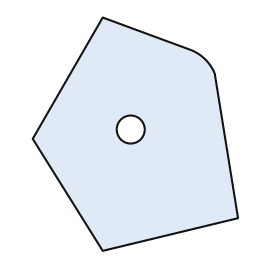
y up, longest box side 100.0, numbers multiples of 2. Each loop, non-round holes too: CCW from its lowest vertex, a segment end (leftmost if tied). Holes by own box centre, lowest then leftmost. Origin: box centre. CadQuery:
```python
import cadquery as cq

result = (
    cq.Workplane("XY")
    .moveTo(-14.0, -50.0)
    .lineTo(44.0, -36.0)
    .lineTo(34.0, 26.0)
    .threePointArc((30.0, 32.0), (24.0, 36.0))
    .lineTo(-14.0, 50.0)
    .lineTo(-44.0, -2.0)
    .close()
    .moveTo(-2.0, 2.0)
    .circle(6.0)
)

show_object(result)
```